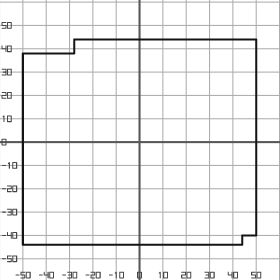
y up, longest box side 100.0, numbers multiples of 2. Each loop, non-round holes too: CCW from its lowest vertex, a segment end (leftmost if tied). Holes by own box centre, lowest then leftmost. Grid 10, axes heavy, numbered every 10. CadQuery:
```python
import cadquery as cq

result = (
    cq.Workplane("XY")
    .moveTo(-50.0, -44.0)
    .lineTo(44.0, -44.0)
    .lineTo(44.0, -40.0)
    .lineTo(50.0, -40.0)
    .lineTo(50.0, 44.0)
    .lineTo(-28.0, 44.0)
    .lineTo(-28.0, 38.0)
    .lineTo(-50.0, 38.0)
    .close()
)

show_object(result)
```